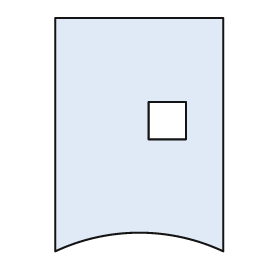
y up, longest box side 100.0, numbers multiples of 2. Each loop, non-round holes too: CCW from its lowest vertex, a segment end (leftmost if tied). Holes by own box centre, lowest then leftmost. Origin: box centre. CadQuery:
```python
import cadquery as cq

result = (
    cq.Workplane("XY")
    .moveTo(-36.0, -50.0)
    .threePointArc((0.0, -42.0), (36.0, -50.0))
    .lineTo(36.0, 50.0)
    .lineTo(-36.0, 50.0)
    .close()
    .moveTo(4.0, -2.0)
    .lineTo(20.0, -2.0)
    .lineTo(20.0, 14.0)
    .lineTo(4.0, 14.0)
    .close()
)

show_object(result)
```